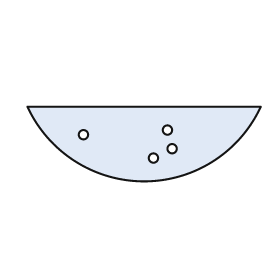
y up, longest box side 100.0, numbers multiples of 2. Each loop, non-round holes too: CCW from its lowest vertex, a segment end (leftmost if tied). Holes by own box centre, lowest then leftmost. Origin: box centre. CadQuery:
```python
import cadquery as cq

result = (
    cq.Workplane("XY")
    .moveTo(-50.0, 16.0)
    .threePointArc((0.0, -16.0), (50.0, 16.0))
    .close()
    .moveTo(4.0, -6.0)
    .circle(2.0)
    .moveTo(12.0, -2.0)
    .circle(2.0)
    .moveTo(-26.0, 4.0)
    .circle(2.0)
    .moveTo(10.0, 6.0)
    .circle(2.0)
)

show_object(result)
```